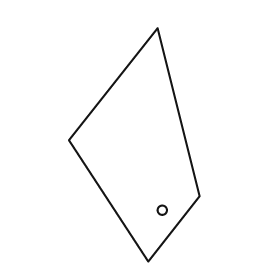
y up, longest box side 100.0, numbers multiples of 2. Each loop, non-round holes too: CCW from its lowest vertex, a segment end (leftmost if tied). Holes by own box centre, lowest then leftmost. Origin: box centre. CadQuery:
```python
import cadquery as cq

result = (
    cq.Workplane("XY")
    .moveTo(6.0, -50.0)
    .lineTo(28.0, -22.0)
    .lineTo(10.0, 50.0)
    .lineTo(-28.0, 2.0)
    .close()
    .moveTo(12.0, -28.0)
    .circle(2.0)
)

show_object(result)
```